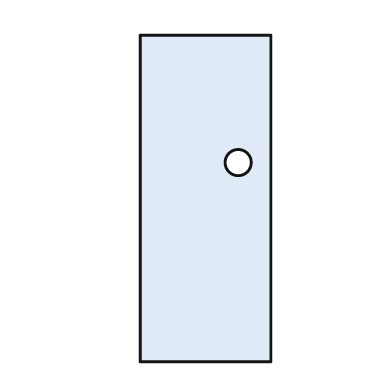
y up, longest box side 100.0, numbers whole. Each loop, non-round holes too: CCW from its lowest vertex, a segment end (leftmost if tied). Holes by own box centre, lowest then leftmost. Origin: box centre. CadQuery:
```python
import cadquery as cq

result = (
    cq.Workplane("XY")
    .moveTo(-20.0, -50.0)
    .lineTo(20.0, -50.0)
    .lineTo(20.0, 50.0)
    .lineTo(-20.0, 50.0)
    .close()
    .moveTo(10.0, 11.0)
    .circle(4.0)
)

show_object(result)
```